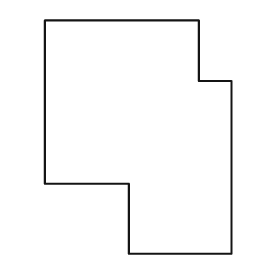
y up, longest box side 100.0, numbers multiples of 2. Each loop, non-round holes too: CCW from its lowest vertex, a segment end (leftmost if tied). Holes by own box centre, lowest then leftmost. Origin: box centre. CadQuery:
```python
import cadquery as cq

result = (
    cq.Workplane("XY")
    .moveTo(-4.0, -50.0)
    .lineTo(40.0, -50.0)
    .lineTo(40.0, 24.0)
    .lineTo(26.0, 24.0)
    .lineTo(26.0, 50.0)
    .lineTo(-40.0, 50.0)
    .lineTo(-40.0, -20.0)
    .lineTo(-4.0, -20.0)
    .close()
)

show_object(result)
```